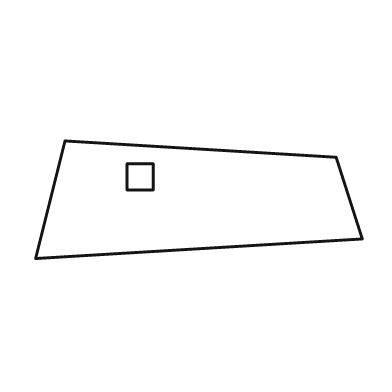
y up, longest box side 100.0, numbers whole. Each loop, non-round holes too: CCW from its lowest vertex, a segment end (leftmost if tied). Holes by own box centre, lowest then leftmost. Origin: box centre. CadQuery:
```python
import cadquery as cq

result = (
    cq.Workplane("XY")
    .moveTo(-50.0, -18.0)
    .lineTo(50.0, -12.0)
    .lineTo(42.0, 13.0)
    .lineTo(-41.0, 18.0)
    .close()
    .moveTo(-22.0, 3.0)
    .lineTo(-14.0, 3.0)
    .lineTo(-14.0, 11.0)
    .lineTo(-22.0, 11.0)
    .close()
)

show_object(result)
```